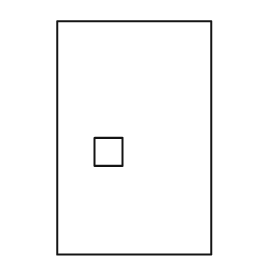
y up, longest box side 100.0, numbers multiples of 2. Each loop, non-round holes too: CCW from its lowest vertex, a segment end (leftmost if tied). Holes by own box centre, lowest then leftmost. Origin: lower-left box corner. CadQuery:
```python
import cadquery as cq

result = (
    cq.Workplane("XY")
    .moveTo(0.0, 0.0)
    .lineTo(66.0, 0.0)
    .lineTo(66.0, 100.0)
    .lineTo(0.0, 100.0)
    .close()
    .moveTo(16.0, 38.0)
    .lineTo(28.0, 38.0)
    .lineTo(28.0, 50.0)
    .lineTo(16.0, 50.0)
    .close()
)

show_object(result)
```